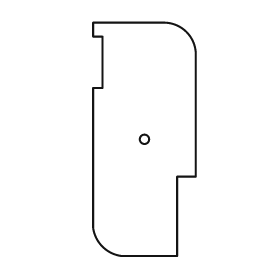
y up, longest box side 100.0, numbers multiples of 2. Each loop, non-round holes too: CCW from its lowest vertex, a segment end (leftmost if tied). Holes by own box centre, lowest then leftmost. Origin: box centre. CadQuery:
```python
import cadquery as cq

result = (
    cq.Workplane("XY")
    .moveTo(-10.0, -50.0)
    .lineTo(14.0, -50.0)
    .lineTo(14.0, -16.0)
    .lineTo(22.0, -16.0)
    .lineTo(22.0, 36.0)
    .threePointArc((18.0, 46.0), (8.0, 50.0))
    .lineTo(-22.0, 50.0)
    .lineTo(-22.0, 44.0)
    .lineTo(-18.0, 44.0)
    .lineTo(-18.0, 22.0)
    .lineTo(-22.0, 22.0)
    .lineTo(-22.0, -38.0)
    .threePointArc((-18.0, -46.0), (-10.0, -50.0))
    .close()
    .moveTo(0.0, 0.0)
    .circle(2.0)
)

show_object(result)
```